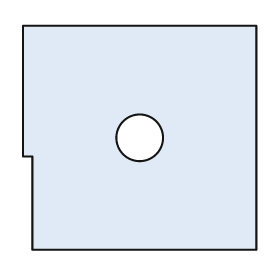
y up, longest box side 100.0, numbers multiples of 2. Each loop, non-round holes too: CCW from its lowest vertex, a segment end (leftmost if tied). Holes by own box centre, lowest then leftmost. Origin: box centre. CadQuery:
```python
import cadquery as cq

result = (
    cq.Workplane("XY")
    .moveTo(-46.0, -48.0)
    .lineTo(50.0, -48.0)
    .lineTo(50.0, 48.0)
    .lineTo(-50.0, 48.0)
    .lineTo(-50.0, -8.0)
    .lineTo(-46.0, -8.0)
    .close()
    .moveTo(0.0, 0.0)
    .circle(10.0)
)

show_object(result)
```